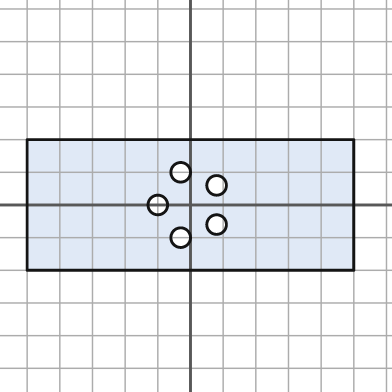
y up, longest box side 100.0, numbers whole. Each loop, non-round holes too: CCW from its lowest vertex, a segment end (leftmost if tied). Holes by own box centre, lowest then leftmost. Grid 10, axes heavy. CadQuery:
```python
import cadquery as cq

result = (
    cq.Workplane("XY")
    .moveTo(-50.0, -20.0)
    .lineTo(50.0, -20.0)
    .lineTo(50.0, 20.0)
    .lineTo(-50.0, 20.0)
    .close()
    .moveTo(-3.0, -10.0)
    .circle(3.0)
    .moveTo(8.0, -6.0)
    .circle(3.0)
    .moveTo(-10.0, 0.0)
    .circle(3.0)
    .moveTo(8.0, 6.0)
    .circle(3.0)
    .moveTo(-3.0, 10.0)
    .circle(3.0)
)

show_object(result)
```